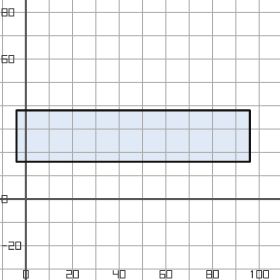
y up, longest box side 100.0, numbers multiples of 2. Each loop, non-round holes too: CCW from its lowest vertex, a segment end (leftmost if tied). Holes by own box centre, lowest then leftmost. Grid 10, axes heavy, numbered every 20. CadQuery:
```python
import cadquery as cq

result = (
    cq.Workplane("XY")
    .moveTo(-4.0, 16.0)
    .lineTo(96.0, 16.0)
    .lineTo(96.0, 38.0)
    .lineTo(-4.0, 38.0)
    .close()
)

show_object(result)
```